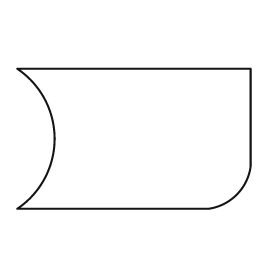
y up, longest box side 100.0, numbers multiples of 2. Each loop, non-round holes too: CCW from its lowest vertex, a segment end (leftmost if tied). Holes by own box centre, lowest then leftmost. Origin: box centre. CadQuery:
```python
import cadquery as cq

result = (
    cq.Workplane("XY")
    .moveTo(-50.0, -30.0)
    .lineTo(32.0, -30.0)
    .threePointArc((44.0, -24.0), (50.0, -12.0))
    .lineTo(50.0, 30.0)
    .lineTo(-50.0, 30.0)
    .threePointArc((-34.0, 0.0), (-50.0, -30.0))
    .close()
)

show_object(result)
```